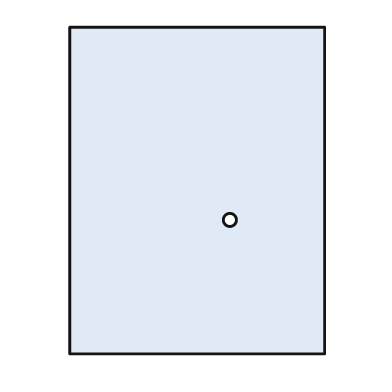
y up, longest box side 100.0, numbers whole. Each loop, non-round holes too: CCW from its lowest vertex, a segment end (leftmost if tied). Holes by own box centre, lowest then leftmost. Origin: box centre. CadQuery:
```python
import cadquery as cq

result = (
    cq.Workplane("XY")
    .moveTo(-39.0, -50.0)
    .lineTo(39.0, -50.0)
    .lineTo(39.0, 50.0)
    .lineTo(-39.0, 50.0)
    .close()
    .moveTo(10.0, -9.0)
    .circle(2.0)
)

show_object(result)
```